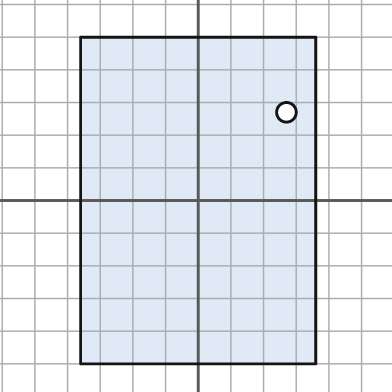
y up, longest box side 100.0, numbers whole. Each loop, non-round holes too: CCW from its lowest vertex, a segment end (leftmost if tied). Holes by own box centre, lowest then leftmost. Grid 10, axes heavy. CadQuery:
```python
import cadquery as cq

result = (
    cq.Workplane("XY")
    .moveTo(-36.0, -50.0)
    .lineTo(36.0, -50.0)
    .lineTo(36.0, 50.0)
    .lineTo(-36.0, 50.0)
    .close()
    .moveTo(27.0, 27.0)
    .circle(3.0)
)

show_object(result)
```